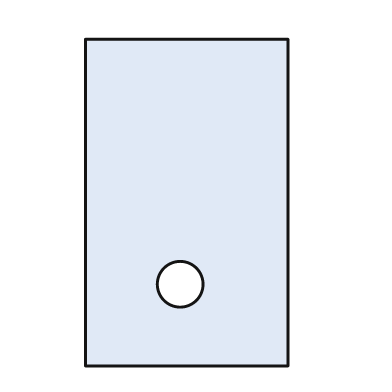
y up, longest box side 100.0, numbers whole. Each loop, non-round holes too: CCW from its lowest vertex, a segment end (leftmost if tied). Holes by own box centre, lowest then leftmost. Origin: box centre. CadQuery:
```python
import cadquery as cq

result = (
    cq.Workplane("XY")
    .moveTo(-31.0, -50.0)
    .lineTo(31.0, -50.0)
    .lineTo(31.0, 50.0)
    .lineTo(-31.0, 50.0)
    .close()
    .moveTo(-2.0, -25.0)
    .circle(7.0)
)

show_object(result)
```